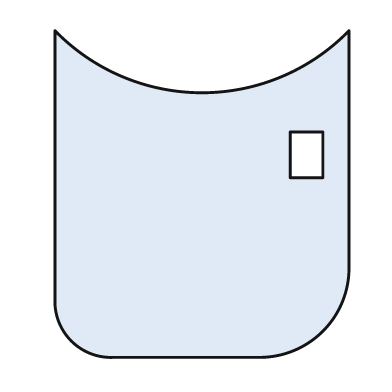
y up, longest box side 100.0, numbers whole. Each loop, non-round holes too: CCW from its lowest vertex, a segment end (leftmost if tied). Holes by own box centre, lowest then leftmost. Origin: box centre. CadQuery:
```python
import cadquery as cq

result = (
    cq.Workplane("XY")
    .moveTo(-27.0, -50.0)
    .lineTo(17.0, -50.0)
    .threePointArc((37.0, -42.0), (45.0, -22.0))
    .lineTo(45.0, 50.0)
    .threePointArc((0.0, 31.0), (-45.0, 50.0))
    .lineTo(-45.0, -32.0)
    .threePointArc((-40.0, -45.0), (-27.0, -50.0))
    .close()
    .moveTo(27.0, 5.0)
    .lineTo(37.0, 5.0)
    .lineTo(37.0, 19.0)
    .lineTo(27.0, 19.0)
    .close()
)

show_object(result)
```